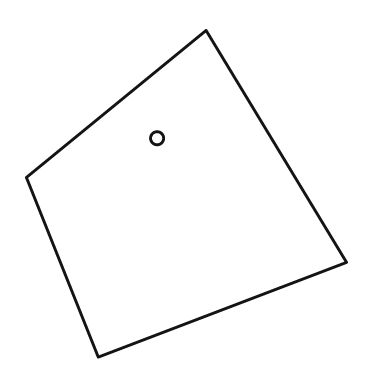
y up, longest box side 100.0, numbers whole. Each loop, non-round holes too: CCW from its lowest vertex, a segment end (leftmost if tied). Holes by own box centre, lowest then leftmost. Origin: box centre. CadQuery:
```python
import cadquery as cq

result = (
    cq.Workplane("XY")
    .moveTo(-27.0, -50.0)
    .lineTo(49.0, -21.0)
    .lineTo(6.0, 50.0)
    .lineTo(-49.0, 5.0)
    .close()
    .moveTo(-9.0, 17.0)
    .circle(2.0)
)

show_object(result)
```